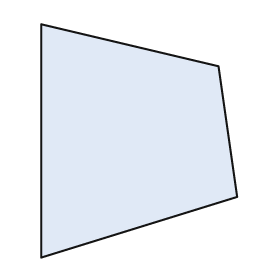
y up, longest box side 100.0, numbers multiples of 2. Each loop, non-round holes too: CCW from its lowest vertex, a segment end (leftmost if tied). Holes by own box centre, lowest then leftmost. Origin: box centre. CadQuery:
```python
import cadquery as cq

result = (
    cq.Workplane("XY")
    .moveTo(-42.0, -50.0)
    .lineTo(42.0, -24.0)
    .lineTo(34.0, 32.0)
    .lineTo(-42.0, 50.0)
    .close()
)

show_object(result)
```